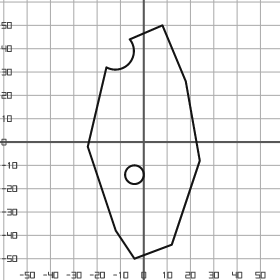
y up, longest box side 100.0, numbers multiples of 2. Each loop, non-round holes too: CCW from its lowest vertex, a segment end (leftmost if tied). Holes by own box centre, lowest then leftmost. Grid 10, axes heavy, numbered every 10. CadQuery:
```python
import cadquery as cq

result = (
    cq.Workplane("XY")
    .moveTo(-4.0, -50.0)
    .lineTo(12.0, -44.0)
    .lineTo(24.0, -8.0)
    .lineTo(18.0, 26.0)
    .lineTo(8.0, 50.0)
    .lineTo(-6.0, 44.0)
    .threePointArc((-6.0, 34.0), (-16.0, 32.0))
    .lineTo(-24.0, -2.0)
    .lineTo(-12.0, -38.0)
    .close()
    .moveTo(-4.0, -14.0)
    .circle(4.0)
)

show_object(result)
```